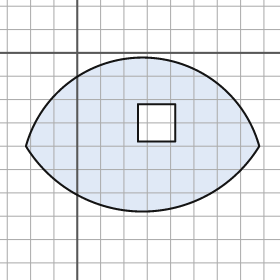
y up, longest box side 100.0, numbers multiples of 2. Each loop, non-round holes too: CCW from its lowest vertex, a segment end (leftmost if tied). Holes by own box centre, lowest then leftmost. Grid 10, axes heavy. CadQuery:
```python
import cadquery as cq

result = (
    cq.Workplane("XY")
    .moveTo(-22.0, -40.0)
    .threePointArc((28.0, -68.0), (78.0, -40.0))
    .threePointArc((28.0, -2.0), (-22.0, -40.0))
    .close()
    .moveTo(26.0, -38.0)
    .lineTo(42.0, -38.0)
    .lineTo(42.0, -22.0)
    .lineTo(26.0, -22.0)
    .close()
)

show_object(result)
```